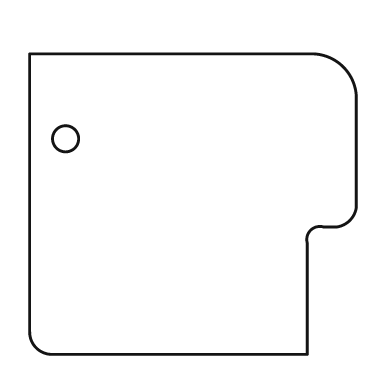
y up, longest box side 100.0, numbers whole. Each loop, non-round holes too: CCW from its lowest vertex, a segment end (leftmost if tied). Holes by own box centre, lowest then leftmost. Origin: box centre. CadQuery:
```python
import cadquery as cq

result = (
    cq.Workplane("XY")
    .moveTo(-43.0, -46.0)
    .lineTo(35.0, -46.0)
    .lineTo(35.0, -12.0)
    .threePointArc((36.0, -8.0), (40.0, -7.0))
    .lineTo(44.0, -7.0)
    .threePointArc((48.0, -5.0), (50.0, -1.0))
    .lineTo(50.0, 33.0)
    .threePointArc((46.0, 42.0), (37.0, 46.0))
    .lineTo(-50.0, 46.0)
    .lineTo(-50.0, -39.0)
    .threePointArc((-48.0, -44.0), (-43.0, -46.0))
    .close()
    .moveTo(-39.0, 20.0)
    .circle(4.0)
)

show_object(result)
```